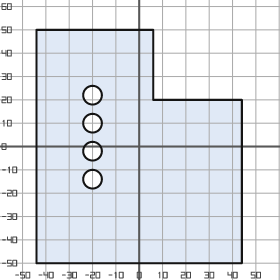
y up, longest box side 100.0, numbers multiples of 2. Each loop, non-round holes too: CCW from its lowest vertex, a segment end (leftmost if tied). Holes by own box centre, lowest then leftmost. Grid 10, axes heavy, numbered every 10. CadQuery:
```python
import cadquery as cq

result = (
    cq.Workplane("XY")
    .moveTo(-44.0, -50.0)
    .lineTo(44.0, -50.0)
    .lineTo(44.0, 20.0)
    .lineTo(6.0, 20.0)
    .lineTo(6.0, 50.0)
    .lineTo(-44.0, 50.0)
    .close()
    .moveTo(-20.0, -14.0)
    .circle(4.0)
    .moveTo(-20.0, -2.0)
    .circle(4.0)
    .moveTo(-20.0, 10.0)
    .circle(4.0)
    .moveTo(-20.0, 22.0)
    .circle(4.0)
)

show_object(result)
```